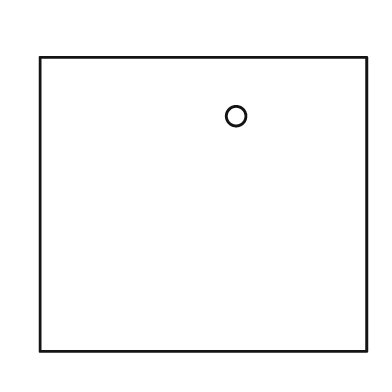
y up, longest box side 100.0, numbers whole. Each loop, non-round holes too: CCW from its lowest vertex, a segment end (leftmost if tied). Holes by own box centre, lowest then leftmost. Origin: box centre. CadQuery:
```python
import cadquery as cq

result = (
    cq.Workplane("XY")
    .moveTo(-50.0, -45.0)
    .lineTo(50.0, -45.0)
    .lineTo(50.0, 45.0)
    .lineTo(-50.0, 45.0)
    .close()
    .moveTo(10.0, 27.0)
    .circle(3.0)
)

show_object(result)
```